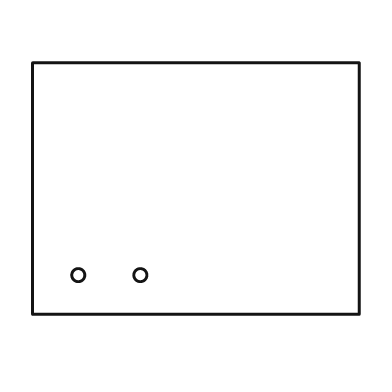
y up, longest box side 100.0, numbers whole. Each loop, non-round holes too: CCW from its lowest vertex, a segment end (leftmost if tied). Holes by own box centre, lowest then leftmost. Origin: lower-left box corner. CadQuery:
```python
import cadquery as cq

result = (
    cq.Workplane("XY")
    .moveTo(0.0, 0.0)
    .lineTo(100.0, 0.0)
    .lineTo(100.0, 77.0)
    .lineTo(0.0, 77.0)
    .close()
    .moveTo(14.0, 12.0)
    .circle(2.0)
    .moveTo(33.0, 12.0)
    .circle(2.0)
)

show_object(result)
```